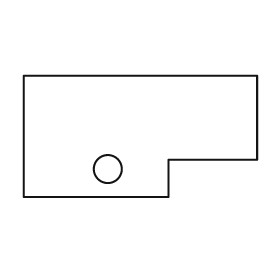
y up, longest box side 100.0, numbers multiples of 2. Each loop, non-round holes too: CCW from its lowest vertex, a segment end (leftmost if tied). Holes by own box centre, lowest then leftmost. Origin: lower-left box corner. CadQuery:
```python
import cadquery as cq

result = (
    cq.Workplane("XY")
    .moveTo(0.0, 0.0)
    .lineTo(62.0, 0.0)
    .lineTo(62.0, 16.0)
    .lineTo(100.0, 16.0)
    .lineTo(100.0, 52.0)
    .lineTo(0.0, 52.0)
    .close()
    .moveTo(36.0, 12.0)
    .circle(6.0)
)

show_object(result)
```